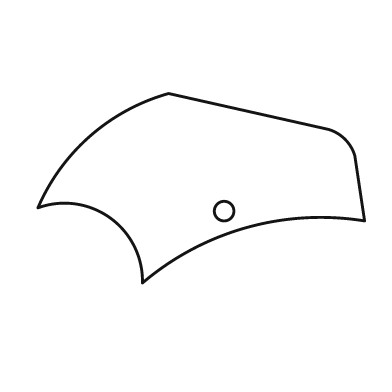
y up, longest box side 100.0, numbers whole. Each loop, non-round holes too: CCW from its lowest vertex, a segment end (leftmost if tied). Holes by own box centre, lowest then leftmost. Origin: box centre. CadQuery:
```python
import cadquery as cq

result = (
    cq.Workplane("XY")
    .moveTo(-18.0, -29.0)
    .threePointArc((14.0, -12.0), (50.0, -10.0))
    .lineTo(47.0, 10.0)
    .threePointArc((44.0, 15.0), (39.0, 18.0))
    .lineTo(-10.0, 29.0)
    .threePointArc((-34.0, 16.0), (-50.0, -6.0))
    .threePointArc((-28.0, -9.0), (-18.0, -29.0))
    .close()
    .moveTo(7.0, -7.0)
    .circle(3.0)
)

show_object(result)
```